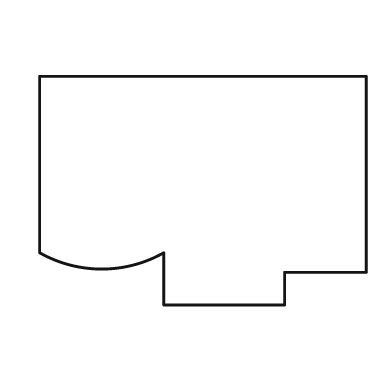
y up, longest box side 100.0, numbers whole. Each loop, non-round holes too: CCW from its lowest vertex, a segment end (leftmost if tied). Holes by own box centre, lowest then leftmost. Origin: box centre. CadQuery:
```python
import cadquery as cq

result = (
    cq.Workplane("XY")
    .moveTo(-12.0, -35.0)
    .lineTo(25.0, -35.0)
    .lineTo(25.0, -25.0)
    .lineTo(50.0, -25.0)
    .lineTo(50.0, 35.0)
    .lineTo(-50.0, 35.0)
    .lineTo(-50.0, -19.0)
    .threePointArc((-31.0, -24.0), (-12.0, -19.0))
    .close()
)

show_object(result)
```